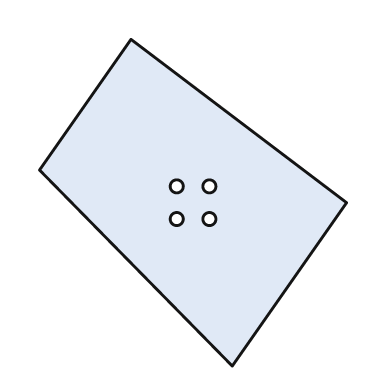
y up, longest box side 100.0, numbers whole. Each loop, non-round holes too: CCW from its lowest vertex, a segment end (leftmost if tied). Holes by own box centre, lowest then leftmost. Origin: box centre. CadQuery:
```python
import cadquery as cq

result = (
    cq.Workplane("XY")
    .moveTo(12.0, -50.0)
    .lineTo(47.0, 0.0)
    .lineTo(-19.0, 50.0)
    .lineTo(-47.0, 10.0)
    .close()
    .moveTo(-5.0, -5.0)
    .circle(2.0)
    .moveTo(5.0, -5.0)
    .circle(2.0)
    .moveTo(-5.0, 5.0)
    .circle(2.0)
    .moveTo(5.0, 5.0)
    .circle(2.0)
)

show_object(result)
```